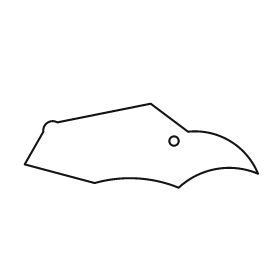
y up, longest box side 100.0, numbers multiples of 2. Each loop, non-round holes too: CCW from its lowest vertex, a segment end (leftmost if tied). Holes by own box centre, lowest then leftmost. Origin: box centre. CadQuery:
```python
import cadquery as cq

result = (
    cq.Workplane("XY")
    .moveTo(16.0, -18.0)
    .threePointArc((32.0, -10.0), (50.0, -12.0))
    .threePointArc((38.0, 2.0), (20.0, 6.0))
    .lineTo(4.0, 18.0)
    .lineTo(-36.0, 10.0)
    .threePointArc((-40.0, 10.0), (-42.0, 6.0))
    .lineTo(-50.0, -8.0)
    .lineTo(-20.0, -16.0)
    .threePointArc((-2.0, -14.0), (16.0, -18.0))
    .close()
    .moveTo(14.0, 2.0)
    .circle(2.0)
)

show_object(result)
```